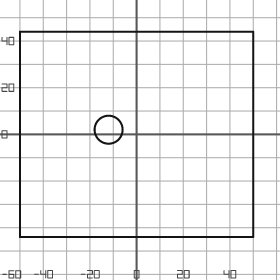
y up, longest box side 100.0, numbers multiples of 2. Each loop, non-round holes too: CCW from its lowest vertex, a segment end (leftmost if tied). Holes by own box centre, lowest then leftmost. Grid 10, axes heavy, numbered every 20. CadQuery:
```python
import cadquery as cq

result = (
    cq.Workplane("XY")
    .moveTo(-50.0, -44.0)
    .lineTo(50.0, -44.0)
    .lineTo(50.0, 44.0)
    .lineTo(-50.0, 44.0)
    .close()
    .moveTo(-12.0, 2.0)
    .circle(6.0)
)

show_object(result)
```